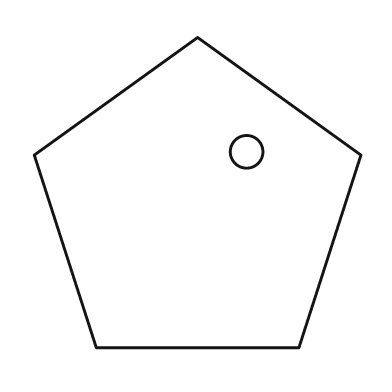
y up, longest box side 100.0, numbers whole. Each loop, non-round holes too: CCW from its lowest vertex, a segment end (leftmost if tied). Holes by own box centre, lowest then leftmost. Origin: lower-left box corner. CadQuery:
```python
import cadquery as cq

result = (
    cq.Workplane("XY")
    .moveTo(19.0, 0.0)
    .lineTo(81.0, 0.0)
    .lineTo(100.0, 59.0)
    .lineTo(50.0, 95.0)
    .lineTo(0.0, 59.0)
    .close()
    .moveTo(65.0, 60.0)
    .circle(5.0)
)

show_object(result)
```